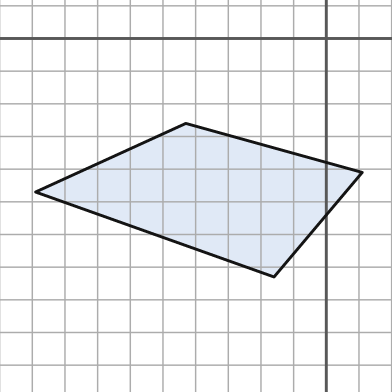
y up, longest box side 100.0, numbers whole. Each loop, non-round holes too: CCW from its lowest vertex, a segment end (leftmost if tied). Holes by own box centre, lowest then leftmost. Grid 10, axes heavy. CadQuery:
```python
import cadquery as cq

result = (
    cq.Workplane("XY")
    .moveTo(-16.0, -73.0)
    .lineTo(11.0, -41.0)
    .lineTo(-43.0, -26.0)
    .lineTo(-89.0, -47.0)
    .close()
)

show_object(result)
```